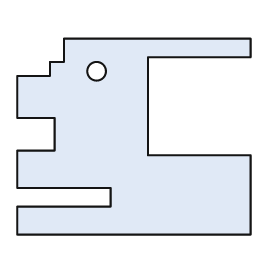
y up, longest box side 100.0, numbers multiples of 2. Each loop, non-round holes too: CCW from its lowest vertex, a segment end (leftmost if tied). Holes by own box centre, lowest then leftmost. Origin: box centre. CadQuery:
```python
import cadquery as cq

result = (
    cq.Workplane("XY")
    .moveTo(-50.0, -42.0)
    .lineTo(50.0, -42.0)
    .lineTo(50.0, -8.0)
    .lineTo(6.0, -8.0)
    .lineTo(6.0, 34.0)
    .lineTo(50.0, 34.0)
    .lineTo(50.0, 42.0)
    .lineTo(-30.0, 42.0)
    .lineTo(-30.0, 32.0)
    .lineTo(-36.0, 32.0)
    .lineTo(-36.0, 26.0)
    .lineTo(-50.0, 26.0)
    .lineTo(-50.0, 8.0)
    .lineTo(-34.0, 8.0)
    .lineTo(-34.0, -6.0)
    .lineTo(-50.0, -6.0)
    .lineTo(-50.0, -22.0)
    .lineTo(-10.0, -22.0)
    .lineTo(-10.0, -30.0)
    .lineTo(-50.0, -30.0)
    .close()
    .moveTo(-16.0, 28.0)
    .circle(4.0)
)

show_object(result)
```